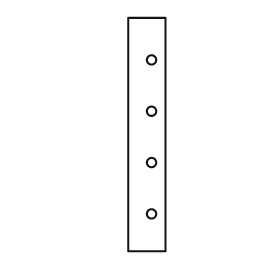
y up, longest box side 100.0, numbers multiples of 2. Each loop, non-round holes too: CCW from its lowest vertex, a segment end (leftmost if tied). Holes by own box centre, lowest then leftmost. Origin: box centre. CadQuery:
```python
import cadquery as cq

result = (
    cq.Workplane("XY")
    .moveTo(-8.0, -50.0)
    .lineTo(8.0, -50.0)
    .lineTo(8.0, 50.0)
    .lineTo(-8.0, 50.0)
    .close()
    .moveTo(2.0, -34.0)
    .circle(2.0)
    .moveTo(2.0, -12.0)
    .circle(2.0)
    .moveTo(2.0, 10.0)
    .circle(2.0)
    .moveTo(2.0, 32.0)
    .circle(2.0)
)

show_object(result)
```